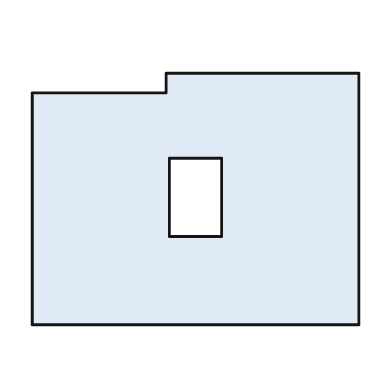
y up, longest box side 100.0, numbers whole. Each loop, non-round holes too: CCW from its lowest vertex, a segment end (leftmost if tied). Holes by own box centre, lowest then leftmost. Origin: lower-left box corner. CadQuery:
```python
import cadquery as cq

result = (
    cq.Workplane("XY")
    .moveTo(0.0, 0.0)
    .lineTo(100.0, 0.0)
    .lineTo(100.0, 77.0)
    .lineTo(41.0, 77.0)
    .lineTo(41.0, 71.0)
    .lineTo(0.0, 71.0)
    .close()
    .moveTo(42.0, 27.0)
    .lineTo(58.0, 27.0)
    .lineTo(58.0, 51.0)
    .lineTo(42.0, 51.0)
    .close()
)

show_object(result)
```